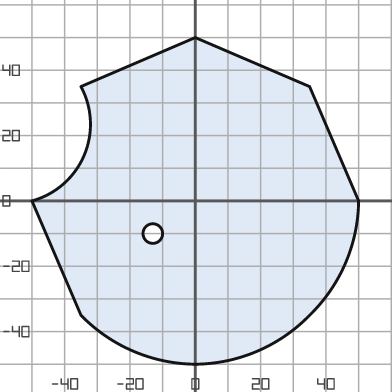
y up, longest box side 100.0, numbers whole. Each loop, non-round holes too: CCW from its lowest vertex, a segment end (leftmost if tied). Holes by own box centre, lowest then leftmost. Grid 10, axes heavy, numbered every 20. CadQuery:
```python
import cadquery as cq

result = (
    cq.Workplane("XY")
    .moveTo(0.0, -50.0)
    .threePointArc((19.0, -46.0), (35.0, -35.0))
    .threePointArc((46.0, -19.0), (50.0, 0.0))
    .lineTo(35.0, 35.0)
    .lineTo(0.0, 50.0)
    .lineTo(-35.0, 35.0)
    .threePointArc((-34.0, 14.0), (-50.0, 0.0))
    .lineTo(-35.0, -35.0)
    .threePointArc((-19.0, -46.0), (0.0, -50.0))
    .close()
    .moveTo(-13.0, -10.0)
    .circle(3.0)
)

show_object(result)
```